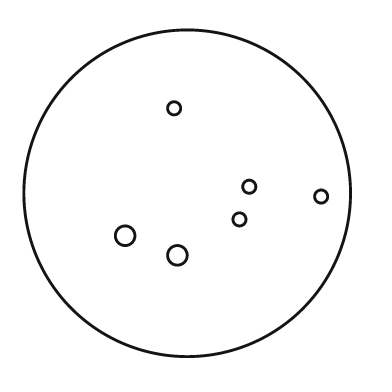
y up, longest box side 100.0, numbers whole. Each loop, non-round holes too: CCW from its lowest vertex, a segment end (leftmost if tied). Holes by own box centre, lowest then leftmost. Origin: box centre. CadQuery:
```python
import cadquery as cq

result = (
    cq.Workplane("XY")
    .moveTo(0.0, 0.0)
    .circle(50.0)
    .moveTo(-3.0, -19.0)
    .circle(3.0)
    .moveTo(-19.0, -13.0)
    .circle(3.0)
    .moveTo(16.0, -8.0)
    .circle(2.0)
    .moveTo(41.0, -1.0)
    .circle(2.0)
    .moveTo(19.0, 2.0)
    .circle(2.0)
    .moveTo(-4.0, 26.0)
    .circle(2.0)
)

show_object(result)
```